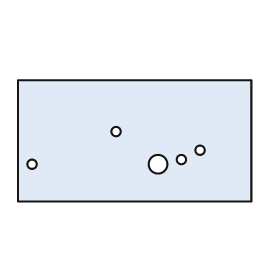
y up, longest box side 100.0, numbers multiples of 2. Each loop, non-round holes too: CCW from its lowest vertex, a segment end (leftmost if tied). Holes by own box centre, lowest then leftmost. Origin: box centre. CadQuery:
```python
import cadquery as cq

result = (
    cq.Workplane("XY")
    .moveTo(-50.0, -26.0)
    .lineTo(50.0, -26.0)
    .lineTo(50.0, 26.0)
    .lineTo(-50.0, 26.0)
    .close()
    .moveTo(-44.0, -10.0)
    .circle(2.0)
    .moveTo(10.0, -10.0)
    .circle(4.0)
    .moveTo(20.0, -8.0)
    .circle(2.0)
    .moveTo(28.0, -4.0)
    .circle(2.0)
    .moveTo(-8.0, 4.0)
    .circle(2.0)
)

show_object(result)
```